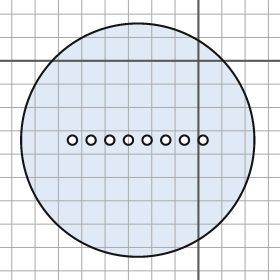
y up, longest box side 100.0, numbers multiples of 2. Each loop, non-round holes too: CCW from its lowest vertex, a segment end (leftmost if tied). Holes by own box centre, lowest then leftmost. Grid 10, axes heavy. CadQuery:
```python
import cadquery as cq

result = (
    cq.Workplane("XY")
    .moveTo(-26.0, -34.0)
    .circle(50.0)
    .moveTo(-54.0, -34.0)
    .circle(2.0)
    .moveTo(-46.0, -34.0)
    .circle(2.0)
    .moveTo(-38.0, -34.0)
    .circle(2.0)
    .moveTo(-30.0, -34.0)
    .circle(2.0)
    .moveTo(-22.0, -34.0)
    .circle(2.0)
    .moveTo(-14.0, -34.0)
    .circle(2.0)
    .moveTo(-6.0, -34.0)
    .circle(2.0)
    .moveTo(2.0, -34.0)
    .circle(2.0)
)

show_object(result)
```